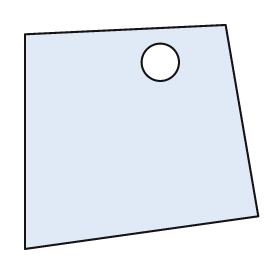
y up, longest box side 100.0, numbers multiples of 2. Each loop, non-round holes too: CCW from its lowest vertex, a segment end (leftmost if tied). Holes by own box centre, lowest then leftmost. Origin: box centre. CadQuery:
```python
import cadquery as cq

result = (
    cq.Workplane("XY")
    .moveTo(-50.0, -48.0)
    .lineTo(50.0, -34.0)
    .lineTo(36.0, 48.0)
    .lineTo(-50.0, 44.0)
    .close()
    .moveTo(8.0, 32.0)
    .circle(8.0)
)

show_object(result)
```